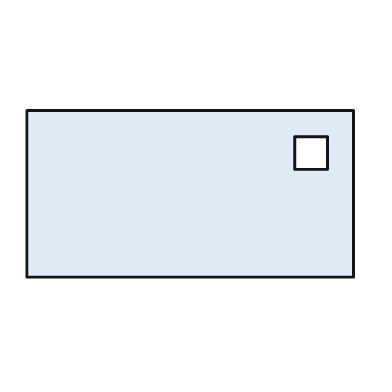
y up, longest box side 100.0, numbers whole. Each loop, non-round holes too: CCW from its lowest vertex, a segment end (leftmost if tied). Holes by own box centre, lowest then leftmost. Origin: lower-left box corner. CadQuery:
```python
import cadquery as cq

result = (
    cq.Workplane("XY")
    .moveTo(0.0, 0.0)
    .lineTo(100.0, 0.0)
    .lineTo(100.0, 51.0)
    .lineTo(0.0, 51.0)
    .close()
    .moveTo(82.0, 33.0)
    .lineTo(92.0, 33.0)
    .lineTo(92.0, 43.0)
    .lineTo(82.0, 43.0)
    .close()
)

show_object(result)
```